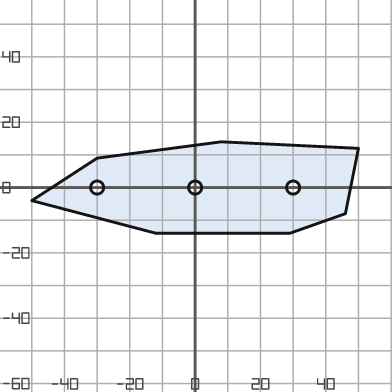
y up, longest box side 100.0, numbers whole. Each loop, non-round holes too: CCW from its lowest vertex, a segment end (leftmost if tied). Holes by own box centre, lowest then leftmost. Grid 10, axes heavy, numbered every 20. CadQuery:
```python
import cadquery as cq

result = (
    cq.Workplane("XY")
    .moveTo(-12.0, -14.0)
    .lineTo(29.0, -14.0)
    .lineTo(46.0, -8.0)
    .lineTo(50.0, 12.0)
    .lineTo(8.0, 14.0)
    .lineTo(-30.0, 9.0)
    .lineTo(-50.0, -4.0)
    .close()
    .moveTo(-30.0, 0.0)
    .circle(2.0)
    .moveTo(0.0, 0.0)
    .circle(2.0)
    .moveTo(30.0, 0.0)
    .circle(2.0)
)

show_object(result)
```